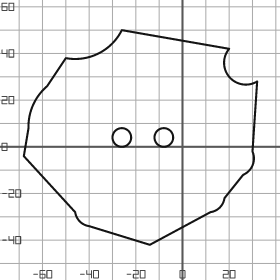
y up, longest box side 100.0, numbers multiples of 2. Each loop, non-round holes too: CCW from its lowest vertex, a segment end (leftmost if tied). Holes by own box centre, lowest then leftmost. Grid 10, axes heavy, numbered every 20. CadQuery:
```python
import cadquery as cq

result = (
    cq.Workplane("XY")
    .moveTo(-14.0, -42.0)
    .lineTo(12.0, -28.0)
    .threePointArc((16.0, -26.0), (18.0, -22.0))
    .lineTo(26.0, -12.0)
    .threePointArc((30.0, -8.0), (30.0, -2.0))
    .lineTo(32.0, 28.0)
    .threePointArc((20.0, 30.0), (20.0, 42.0))
    .lineTo(-26.0, 50.0)
    .threePointArc((-36.0, 40.0), (-50.0, 38.0))
    .lineTo(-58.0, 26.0)
    .threePointArc((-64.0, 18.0), (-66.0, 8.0))
    .lineTo(-68.0, -4.0)
    .lineTo(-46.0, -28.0)
    .threePointArc((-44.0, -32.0), (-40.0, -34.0))
    .close()
    .moveTo(-26.0, 4.0)
    .circle(4.0)
    .moveTo(-8.0, 4.0)
    .circle(4.0)
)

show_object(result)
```